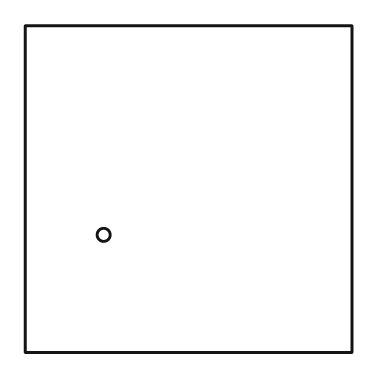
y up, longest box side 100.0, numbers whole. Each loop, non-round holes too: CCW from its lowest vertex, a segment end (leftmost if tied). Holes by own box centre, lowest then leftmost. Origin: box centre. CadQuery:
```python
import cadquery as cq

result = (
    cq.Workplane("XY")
    .moveTo(-50.0, -50.0)
    .lineTo(50.0, -50.0)
    .lineTo(50.0, 50.0)
    .lineTo(-50.0, 50.0)
    .close()
    .moveTo(-26.0, -14.0)
    .circle(2.0)
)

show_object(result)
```